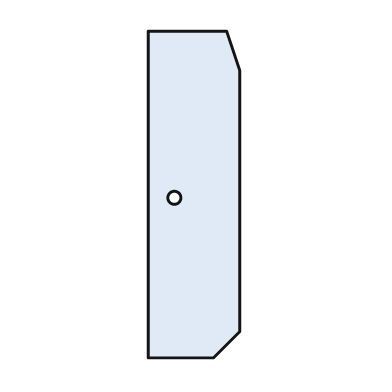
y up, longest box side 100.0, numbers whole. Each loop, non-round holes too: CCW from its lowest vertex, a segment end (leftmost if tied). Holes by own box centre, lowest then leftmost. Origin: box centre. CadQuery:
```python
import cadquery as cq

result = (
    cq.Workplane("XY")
    .moveTo(-14.0, -50.0)
    .lineTo(6.0, -50.0)
    .lineTo(14.0, -42.0)
    .lineTo(14.0, 38.0)
    .lineTo(10.0, 50.0)
    .lineTo(-14.0, 50.0)
    .close()
    .moveTo(-6.0, -1.0)
    .circle(2.0)
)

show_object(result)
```